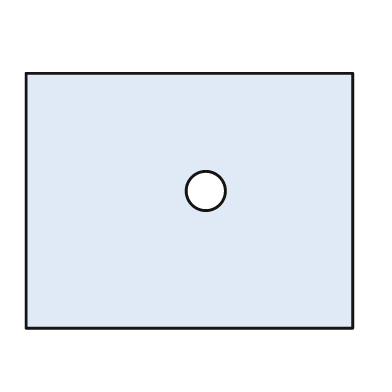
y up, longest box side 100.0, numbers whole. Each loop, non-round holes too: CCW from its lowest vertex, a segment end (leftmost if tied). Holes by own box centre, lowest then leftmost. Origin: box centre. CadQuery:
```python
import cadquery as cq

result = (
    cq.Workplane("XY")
    .moveTo(-50.0, -39.0)
    .lineTo(50.0, -39.0)
    .lineTo(50.0, 39.0)
    .lineTo(-50.0, 39.0)
    .close()
    .moveTo(5.0, 3.0)
    .circle(6.0)
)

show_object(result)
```